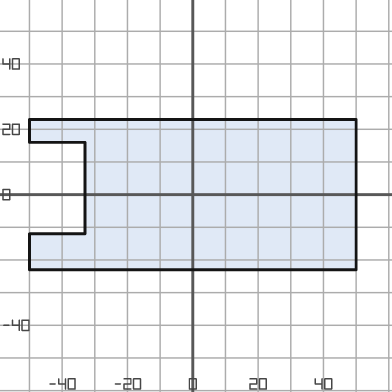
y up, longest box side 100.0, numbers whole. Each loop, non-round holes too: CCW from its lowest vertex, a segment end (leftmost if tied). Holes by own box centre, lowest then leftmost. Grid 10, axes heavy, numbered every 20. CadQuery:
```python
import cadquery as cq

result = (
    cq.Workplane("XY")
    .moveTo(-50.0, -23.0)
    .lineTo(50.0, -23.0)
    .lineTo(50.0, 23.0)
    .lineTo(-50.0, 23.0)
    .lineTo(-50.0, 16.0)
    .lineTo(-33.0, 16.0)
    .lineTo(-33.0, -12.0)
    .lineTo(-50.0, -12.0)
    .close()
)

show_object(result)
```